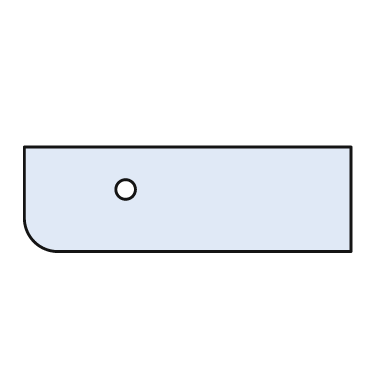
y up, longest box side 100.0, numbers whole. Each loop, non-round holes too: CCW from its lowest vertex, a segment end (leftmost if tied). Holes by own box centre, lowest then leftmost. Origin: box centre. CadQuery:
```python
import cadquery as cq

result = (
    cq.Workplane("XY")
    .moveTo(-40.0, -16.0)
    .lineTo(50.0, -16.0)
    .lineTo(50.0, 16.0)
    .lineTo(-50.0, 16.0)
    .lineTo(-50.0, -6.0)
    .threePointArc((-47.0, -13.0), (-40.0, -16.0))
    .close()
    .moveTo(-19.0, 3.0)
    .circle(3.0)
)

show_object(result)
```